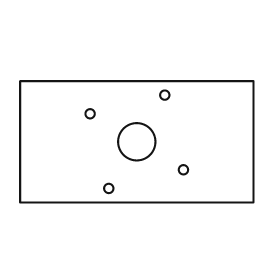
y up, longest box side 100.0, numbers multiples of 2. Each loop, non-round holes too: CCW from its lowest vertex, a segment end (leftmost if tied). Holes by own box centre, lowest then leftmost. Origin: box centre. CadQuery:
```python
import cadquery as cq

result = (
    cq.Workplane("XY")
    .moveTo(-50.0, -26.0)
    .lineTo(50.0, -26.0)
    .lineTo(50.0, 26.0)
    .lineTo(-50.0, 26.0)
    .close()
    .moveTo(-12.0, -20.0)
    .circle(2.0)
    .moveTo(20.0, -12.0)
    .circle(2.0)
    .moveTo(0.0, 0.0)
    .circle(8.0)
    .moveTo(-20.0, 12.0)
    .circle(2.0)
    .moveTo(12.0, 20.0)
    .circle(2.0)
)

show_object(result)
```